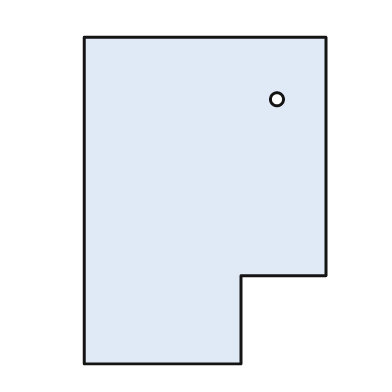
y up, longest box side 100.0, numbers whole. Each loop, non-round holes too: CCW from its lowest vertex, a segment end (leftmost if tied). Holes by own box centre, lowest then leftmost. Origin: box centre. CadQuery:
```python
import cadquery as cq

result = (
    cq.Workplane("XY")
    .moveTo(-37.0, -50.0)
    .lineTo(11.0, -50.0)
    .lineTo(11.0, -23.0)
    .lineTo(37.0, -23.0)
    .lineTo(37.0, 50.0)
    .lineTo(-37.0, 50.0)
    .close()
    .moveTo(22.0, 31.0)
    .circle(2.0)
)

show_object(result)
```